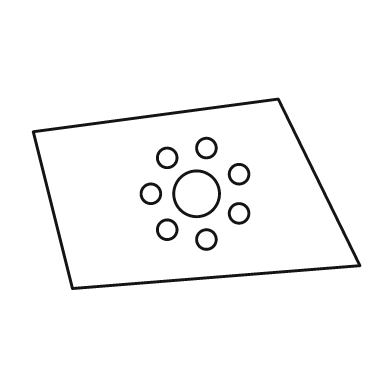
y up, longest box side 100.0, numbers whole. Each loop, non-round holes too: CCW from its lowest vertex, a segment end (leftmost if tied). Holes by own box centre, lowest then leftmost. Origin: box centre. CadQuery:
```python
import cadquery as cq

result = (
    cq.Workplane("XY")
    .moveTo(-38.0, -29.0)
    .lineTo(50.0, -22.0)
    .lineTo(25.0, 29.0)
    .lineTo(-50.0, 19.0)
    .close()
    .moveTo(3.0, -14.0)
    .circle(3.0)
    .moveTo(-9.0, -11.0)
    .circle(3.0)
    .moveTo(13.0, -6.0)
    .circle(3.0)
    .moveTo(-14.0, 0.0)
    .circle(3.0)
    .moveTo(0.0, 0.0)
    .circle(7.0)
    .moveTo(13.0, 6.0)
    .circle(3.0)
    .moveTo(-9.0, 11.0)
    .circle(3.0)
    .moveTo(3.0, 14.0)
    .circle(3.0)
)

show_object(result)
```